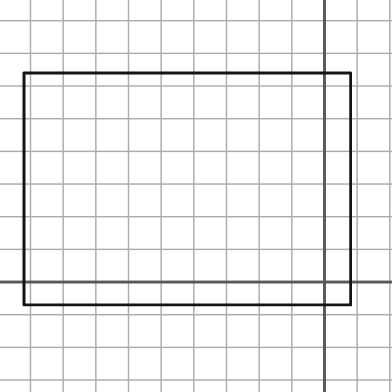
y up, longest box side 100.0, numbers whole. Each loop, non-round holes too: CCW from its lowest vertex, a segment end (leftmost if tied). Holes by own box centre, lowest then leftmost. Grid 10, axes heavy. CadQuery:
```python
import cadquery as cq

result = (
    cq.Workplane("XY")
    .moveTo(-92.0, -7.0)
    .lineTo(8.0, -7.0)
    .lineTo(8.0, 64.0)
    .lineTo(-92.0, 64.0)
    .close()
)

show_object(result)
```